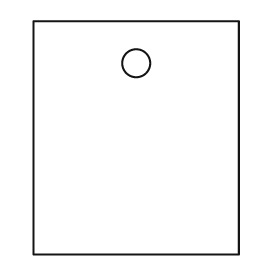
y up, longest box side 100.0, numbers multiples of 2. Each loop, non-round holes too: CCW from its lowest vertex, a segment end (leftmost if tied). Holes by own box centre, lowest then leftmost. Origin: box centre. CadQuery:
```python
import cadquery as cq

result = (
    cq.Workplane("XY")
    .moveTo(-44.0, -50.0)
    .lineTo(44.0, -50.0)
    .lineTo(44.0, 50.0)
    .lineTo(-44.0, 50.0)
    .close()
    .moveTo(0.0, 32.0)
    .circle(6.0)
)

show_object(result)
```